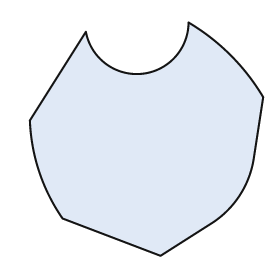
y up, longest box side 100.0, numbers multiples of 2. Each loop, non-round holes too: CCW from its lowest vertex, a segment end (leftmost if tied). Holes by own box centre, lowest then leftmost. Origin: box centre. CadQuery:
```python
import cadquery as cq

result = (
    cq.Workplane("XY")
    .moveTo(6.0, -50.0)
    .lineTo(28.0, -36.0)
    .threePointArc((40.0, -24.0), (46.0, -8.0))
    .lineTo(50.0, 18.0)
    .threePointArc((36.0, 36.0), (18.0, 50.0))
    .threePointArc((-2.0, 28.0), (-26.0, 46.0))
    .lineTo(-50.0, 8.0)
    .threePointArc((-46.0, -14.0), (-36.0, -34.0))
    .close()
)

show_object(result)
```